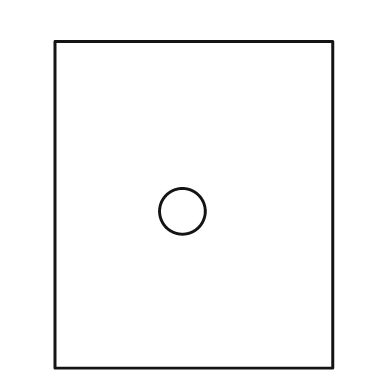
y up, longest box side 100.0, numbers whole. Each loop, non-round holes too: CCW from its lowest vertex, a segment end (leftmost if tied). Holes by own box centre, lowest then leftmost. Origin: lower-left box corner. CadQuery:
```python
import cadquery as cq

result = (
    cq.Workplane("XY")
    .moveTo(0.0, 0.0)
    .lineTo(85.0, 0.0)
    .lineTo(85.0, 100.0)
    .lineTo(0.0, 100.0)
    .close()
    .moveTo(39.0, 48.0)
    .circle(7.0)
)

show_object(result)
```